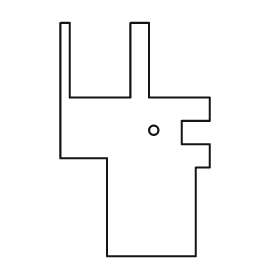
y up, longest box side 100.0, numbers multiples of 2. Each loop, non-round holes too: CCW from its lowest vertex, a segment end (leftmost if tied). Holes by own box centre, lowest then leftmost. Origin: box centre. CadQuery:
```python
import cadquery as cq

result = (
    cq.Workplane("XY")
    .moveTo(-12.0, -50.0)
    .lineTo(26.0, -50.0)
    .lineTo(26.0, -12.0)
    .lineTo(32.0, -12.0)
    .lineTo(32.0, -2.0)
    .lineTo(20.0, -2.0)
    .lineTo(20.0, 8.0)
    .lineTo(32.0, 8.0)
    .lineTo(32.0, 18.0)
    .lineTo(6.0, 18.0)
    .lineTo(6.0, 50.0)
    .lineTo(-2.0, 50.0)
    .lineTo(-2.0, 18.0)
    .lineTo(-28.0, 18.0)
    .lineTo(-28.0, 50.0)
    .lineTo(-32.0, 50.0)
    .lineTo(-32.0, -8.0)
    .lineTo(-12.0, -8.0)
    .close()
    .moveTo(8.0, 4.0)
    .circle(2.0)
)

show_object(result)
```